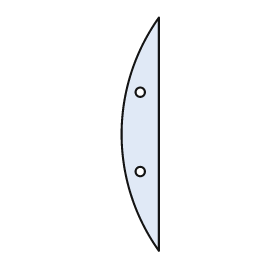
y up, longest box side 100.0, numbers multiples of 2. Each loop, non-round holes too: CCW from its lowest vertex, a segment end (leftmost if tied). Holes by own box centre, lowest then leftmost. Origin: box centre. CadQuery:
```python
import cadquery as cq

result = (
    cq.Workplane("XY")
    .moveTo(8.0, -50.0)
    .lineTo(8.0, 50.0)
    .threePointArc((-8.0, 0.0), (8.0, -50.0))
    .close()
    .moveTo(0.0, -16.0)
    .circle(2.0)
    .moveTo(0.0, 18.0)
    .circle(2.0)
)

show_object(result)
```